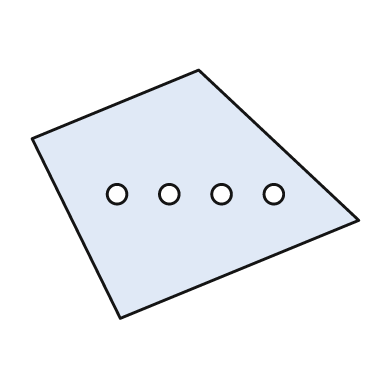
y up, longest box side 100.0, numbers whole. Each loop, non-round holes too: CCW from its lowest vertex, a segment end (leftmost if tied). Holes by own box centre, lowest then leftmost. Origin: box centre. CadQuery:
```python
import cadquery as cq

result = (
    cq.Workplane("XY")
    .moveTo(-23.0, -38.0)
    .lineTo(50.0, -8.0)
    .lineTo(1.0, 38.0)
    .lineTo(-50.0, 17.0)
    .close()
    .moveTo(-24.0, 0.0)
    .circle(3.0)
    .moveTo(-8.0, 0.0)
    .circle(3.0)
    .moveTo(8.0, 0.0)
    .circle(3.0)
    .moveTo(24.0, 0.0)
    .circle(3.0)
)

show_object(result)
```